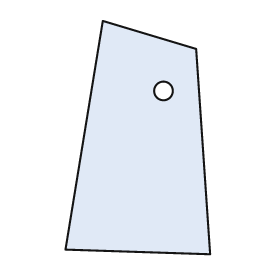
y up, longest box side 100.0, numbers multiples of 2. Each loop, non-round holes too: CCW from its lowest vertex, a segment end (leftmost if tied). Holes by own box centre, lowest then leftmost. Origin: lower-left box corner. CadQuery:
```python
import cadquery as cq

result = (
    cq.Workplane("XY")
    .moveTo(62.0, 0.0)
    .lineTo(56.0, 88.0)
    .lineTo(16.0, 100.0)
    .lineTo(0.0, 2.0)
    .close()
    .moveTo(42.0, 70.0)
    .circle(4.0)
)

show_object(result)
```